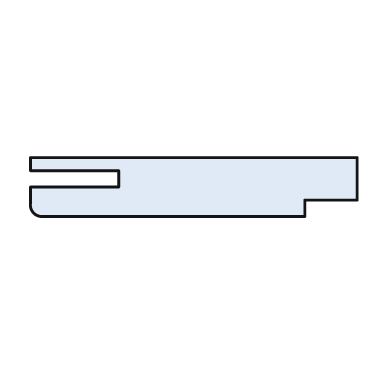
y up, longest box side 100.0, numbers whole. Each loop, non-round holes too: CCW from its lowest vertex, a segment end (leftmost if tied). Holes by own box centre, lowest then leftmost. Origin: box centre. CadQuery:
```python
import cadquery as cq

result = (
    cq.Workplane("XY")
    .moveTo(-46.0, -9.0)
    .lineTo(34.0, -9.0)
    .lineTo(34.0, -4.0)
    .lineTo(50.0, -4.0)
    .lineTo(50.0, 9.0)
    .lineTo(-50.0, 9.0)
    .lineTo(-50.0, 5.0)
    .lineTo(-23.0, 5.0)
    .lineTo(-23.0, 0.0)
    .lineTo(-50.0, 0.0)
    .lineTo(-50.0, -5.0)
    .threePointArc((-49.0, -8.0), (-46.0, -9.0))
    .close()
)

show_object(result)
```